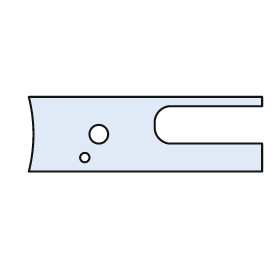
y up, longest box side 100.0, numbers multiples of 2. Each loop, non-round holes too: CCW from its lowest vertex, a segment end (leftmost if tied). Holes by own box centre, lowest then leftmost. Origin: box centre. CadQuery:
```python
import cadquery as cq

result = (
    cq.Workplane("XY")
    .moveTo(-50.0, -16.0)
    .lineTo(50.0, -16.0)
    .lineTo(50.0, -4.0)
    .lineTo(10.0, -4.0)
    .threePointArc((6.0, -2.0), (4.0, 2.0))
    .lineTo(4.0, 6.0)
    .threePointArc((6.0, 10.0), (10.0, 12.0))
    .lineTo(50.0, 12.0)
    .lineTo(50.0, 16.0)
    .lineTo(-50.0, 16.0)
    .threePointArc((-48.0, 0.0), (-50.0, -16.0))
    .close()
    .moveTo(-26.0, -10.0)
    .circle(2.0)
    .moveTo(-20.0, 0.0)
    .circle(4.0)
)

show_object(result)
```